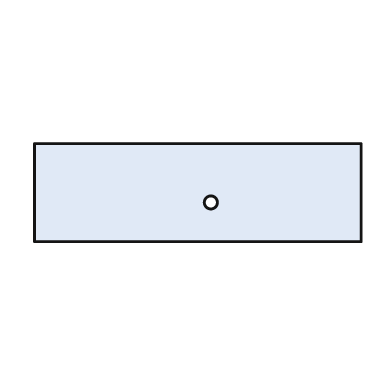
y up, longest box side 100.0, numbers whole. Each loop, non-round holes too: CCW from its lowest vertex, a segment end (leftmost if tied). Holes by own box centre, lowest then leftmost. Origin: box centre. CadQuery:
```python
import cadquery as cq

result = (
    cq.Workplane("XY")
    .moveTo(-50.0, -15.0)
    .lineTo(50.0, -15.0)
    .lineTo(50.0, 15.0)
    .lineTo(-50.0, 15.0)
    .close()
    .moveTo(4.0, -3.0)
    .circle(2.0)
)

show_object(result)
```